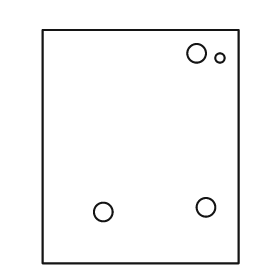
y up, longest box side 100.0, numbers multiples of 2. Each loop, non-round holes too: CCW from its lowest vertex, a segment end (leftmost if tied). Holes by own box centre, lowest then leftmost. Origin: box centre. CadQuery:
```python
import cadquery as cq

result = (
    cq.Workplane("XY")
    .moveTo(-42.0, -50.0)
    .lineTo(42.0, -50.0)
    .lineTo(42.0, 50.0)
    .lineTo(-42.0, 50.0)
    .close()
    .moveTo(-16.0, -28.0)
    .circle(4.0)
    .moveTo(28.0, -26.0)
    .circle(4.0)
    .moveTo(34.0, 38.0)
    .circle(2.0)
    .moveTo(24.0, 40.0)
    .circle(4.0)
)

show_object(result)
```